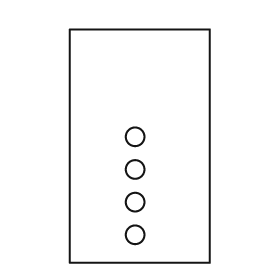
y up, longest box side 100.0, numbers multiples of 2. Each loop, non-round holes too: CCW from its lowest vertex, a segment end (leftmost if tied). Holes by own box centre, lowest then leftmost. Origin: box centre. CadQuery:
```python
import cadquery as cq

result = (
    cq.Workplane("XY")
    .moveTo(-30.0, -50.0)
    .lineTo(30.0, -50.0)
    .lineTo(30.0, 50.0)
    .lineTo(-30.0, 50.0)
    .close()
    .moveTo(-2.0, -38.0)
    .circle(4.0)
    .moveTo(-2.0, -24.0)
    .circle(4.0)
    .moveTo(-2.0, -10.0)
    .circle(4.0)
    .moveTo(-2.0, 4.0)
    .circle(4.0)
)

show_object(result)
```